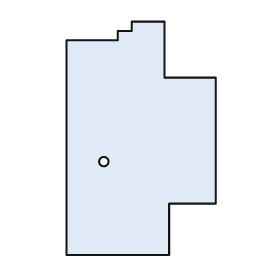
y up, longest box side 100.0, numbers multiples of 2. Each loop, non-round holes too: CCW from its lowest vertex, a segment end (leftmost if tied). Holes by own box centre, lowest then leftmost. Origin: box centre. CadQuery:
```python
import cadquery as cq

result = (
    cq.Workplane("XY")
    .moveTo(-32.0, -50.0)
    .lineTo(12.0, -50.0)
    .lineTo(12.0, -28.0)
    .lineTo(32.0, -28.0)
    .lineTo(32.0, 26.0)
    .lineTo(10.0, 26.0)
    .lineTo(10.0, 50.0)
    .lineTo(-4.0, 50.0)
    .lineTo(-4.0, 46.0)
    .lineTo(-10.0, 46.0)
    .lineTo(-10.0, 42.0)
    .lineTo(-32.0, 42.0)
    .close()
    .moveTo(-16.0, -10.0)
    .circle(2.0)
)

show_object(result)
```